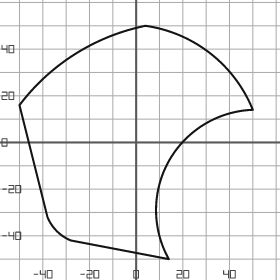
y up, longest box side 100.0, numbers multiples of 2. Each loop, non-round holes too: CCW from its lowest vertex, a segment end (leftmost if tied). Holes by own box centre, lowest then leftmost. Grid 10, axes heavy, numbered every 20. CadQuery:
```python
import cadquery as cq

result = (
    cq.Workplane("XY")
    .moveTo(14.0, -50.0)
    .threePointArc((14.0, -8.0), (50.0, 14.0))
    .threePointArc((32.0, 38.0), (4.0, 50.0))
    .threePointArc((-26.0, 38.0), (-50.0, 16.0))
    .lineTo(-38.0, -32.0)
    .threePointArc((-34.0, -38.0), (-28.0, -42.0))
    .close()
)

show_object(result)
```